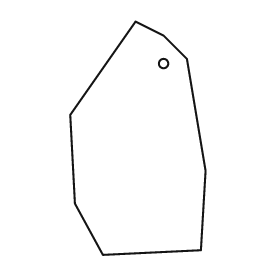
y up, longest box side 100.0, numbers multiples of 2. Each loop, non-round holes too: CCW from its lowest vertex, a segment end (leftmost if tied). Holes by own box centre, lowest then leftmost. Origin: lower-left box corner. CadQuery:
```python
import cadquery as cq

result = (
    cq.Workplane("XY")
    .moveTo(14.0, 0.0)
    .lineTo(56.0, 2.0)
    .lineTo(58.0, 36.0)
    .lineTo(50.0, 84.0)
    .lineTo(40.0, 94.0)
    .lineTo(28.0, 100.0)
    .lineTo(0.0, 60.0)
    .lineTo(2.0, 22.0)
    .close()
    .moveTo(40.0, 82.0)
    .circle(2.0)
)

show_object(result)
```